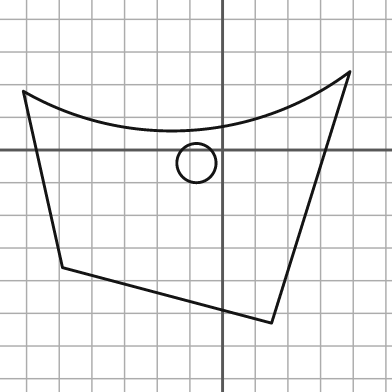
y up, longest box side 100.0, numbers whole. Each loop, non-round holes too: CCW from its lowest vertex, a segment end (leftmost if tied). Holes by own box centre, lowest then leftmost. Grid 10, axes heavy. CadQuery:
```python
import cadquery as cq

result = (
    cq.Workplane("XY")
    .moveTo(15.0, -53.0)
    .lineTo(39.0, 24.0)
    .threePointArc((-10.0, 6.0), (-61.0, 18.0))
    .lineTo(-49.0, -36.0)
    .close()
    .moveTo(-8.0, -4.0)
    .circle(6.0)
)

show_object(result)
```